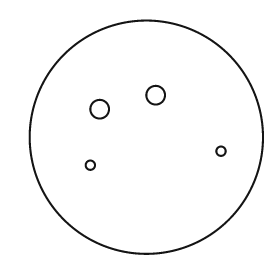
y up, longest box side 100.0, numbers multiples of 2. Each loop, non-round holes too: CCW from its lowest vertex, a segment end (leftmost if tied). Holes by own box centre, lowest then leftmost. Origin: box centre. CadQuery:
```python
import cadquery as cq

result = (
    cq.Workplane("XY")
    .moveTo(0.0, 0.0)
    .circle(50.0)
    .moveTo(-24.0, -12.0)
    .circle(2.0)
    .moveTo(32.0, -6.0)
    .circle(2.0)
    .moveTo(-20.0, 12.0)
    .circle(4.0)
    .moveTo(4.0, 18.0)
    .circle(4.0)
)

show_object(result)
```